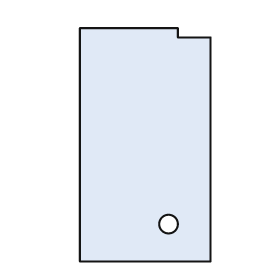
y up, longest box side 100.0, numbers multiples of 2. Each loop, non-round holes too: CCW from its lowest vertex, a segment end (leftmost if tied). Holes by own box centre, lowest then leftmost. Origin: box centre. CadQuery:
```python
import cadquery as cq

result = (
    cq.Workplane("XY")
    .moveTo(-28.0, -50.0)
    .lineTo(28.0, -50.0)
    .lineTo(28.0, 46.0)
    .lineTo(14.0, 46.0)
    .lineTo(14.0, 50.0)
    .lineTo(-28.0, 50.0)
    .close()
    .moveTo(10.0, -34.0)
    .circle(4.0)
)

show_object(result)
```